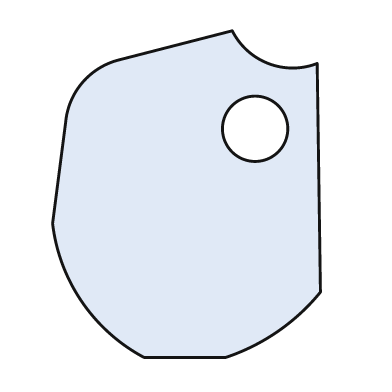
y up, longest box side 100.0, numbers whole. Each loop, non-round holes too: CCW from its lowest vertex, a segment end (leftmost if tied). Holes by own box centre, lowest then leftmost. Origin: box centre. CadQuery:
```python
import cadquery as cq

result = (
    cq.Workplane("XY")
    .moveTo(-13.0, -50.0)
    .lineTo(12.0, -50.0)
    .threePointArc((28.0, -42.0), (41.0, -30.0))
    .lineTo(40.0, 40.0)
    .threePointArc((25.0, 40.0), (14.0, 50.0))
    .lineTo(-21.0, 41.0)
    .threePointArc((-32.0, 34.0), (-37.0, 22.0))
    .lineTo(-41.0, -9.0)
    .threePointArc((-32.0, -33.0), (-13.0, -50.0))
    .close()
    .moveTo(21.0, 20.0)
    .circle(10.0)
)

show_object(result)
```